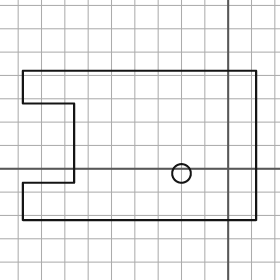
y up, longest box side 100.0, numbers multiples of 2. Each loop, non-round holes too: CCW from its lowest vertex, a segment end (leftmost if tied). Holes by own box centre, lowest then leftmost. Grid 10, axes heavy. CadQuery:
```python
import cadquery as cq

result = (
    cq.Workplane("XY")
    .moveTo(-88.0, -22.0)
    .lineTo(12.0, -22.0)
    .lineTo(12.0, 42.0)
    .lineTo(-88.0, 42.0)
    .lineTo(-88.0, 28.0)
    .lineTo(-66.0, 28.0)
    .lineTo(-66.0, -6.0)
    .lineTo(-88.0, -6.0)
    .close()
    .moveTo(-20.0, -2.0)
    .circle(4.0)
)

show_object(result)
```